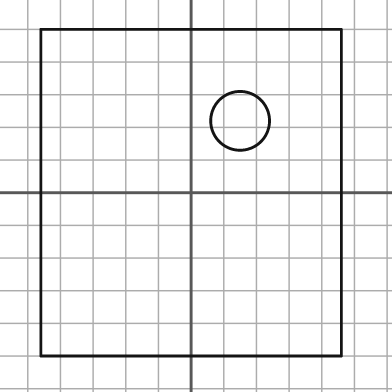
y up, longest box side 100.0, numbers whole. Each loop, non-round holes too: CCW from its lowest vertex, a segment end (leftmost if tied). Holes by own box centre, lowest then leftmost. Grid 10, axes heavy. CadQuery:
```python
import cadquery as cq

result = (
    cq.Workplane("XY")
    .moveTo(-46.0, -50.0)
    .lineTo(46.0, -50.0)
    .lineTo(46.0, 50.0)
    .lineTo(-46.0, 50.0)
    .close()
    .moveTo(15.0, 22.0)
    .circle(9.0)
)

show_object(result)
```